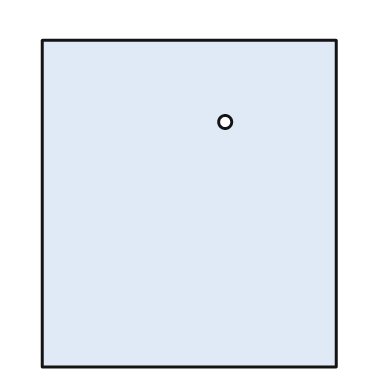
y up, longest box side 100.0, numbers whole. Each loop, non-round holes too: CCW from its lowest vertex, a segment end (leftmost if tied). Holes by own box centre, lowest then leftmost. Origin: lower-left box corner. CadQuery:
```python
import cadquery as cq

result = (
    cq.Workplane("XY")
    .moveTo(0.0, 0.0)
    .lineTo(90.0, 0.0)
    .lineTo(90.0, 100.0)
    .lineTo(0.0, 100.0)
    .close()
    .moveTo(56.0, 75.0)
    .circle(2.0)
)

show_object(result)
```